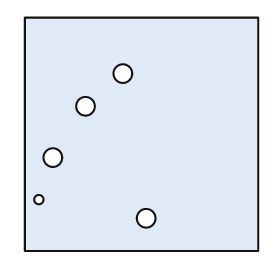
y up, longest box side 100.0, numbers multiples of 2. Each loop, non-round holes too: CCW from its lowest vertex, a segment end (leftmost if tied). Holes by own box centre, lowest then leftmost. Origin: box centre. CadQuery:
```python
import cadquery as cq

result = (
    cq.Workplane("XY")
    .moveTo(-50.0, -50.0)
    .lineTo(50.0, -50.0)
    .lineTo(50.0, 50.0)
    .lineTo(-50.0, 50.0)
    .close()
    .moveTo(2.0, -36.0)
    .circle(4.0)
    .moveTo(-44.0, -28.0)
    .circle(2.0)
    .moveTo(-38.0, -10.0)
    .circle(4.0)
    .moveTo(-24.0, 12.0)
    .circle(4.0)
    .moveTo(-8.0, 26.0)
    .circle(4.0)
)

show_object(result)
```